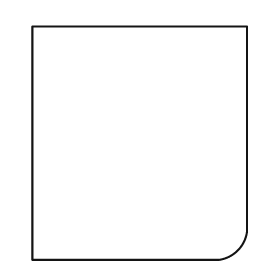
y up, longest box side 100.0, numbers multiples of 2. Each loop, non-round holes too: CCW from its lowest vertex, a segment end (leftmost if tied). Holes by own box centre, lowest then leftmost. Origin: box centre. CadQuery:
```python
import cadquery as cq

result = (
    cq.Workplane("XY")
    .moveTo(-46.0, -50.0)
    .lineTo(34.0, -50.0)
    .threePointArc((42.0, -46.0), (46.0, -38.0))
    .lineTo(46.0, 50.0)
    .lineTo(-46.0, 50.0)
    .close()
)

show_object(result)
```